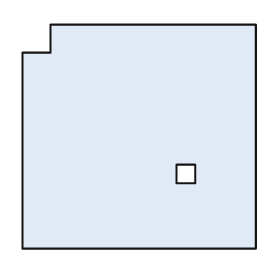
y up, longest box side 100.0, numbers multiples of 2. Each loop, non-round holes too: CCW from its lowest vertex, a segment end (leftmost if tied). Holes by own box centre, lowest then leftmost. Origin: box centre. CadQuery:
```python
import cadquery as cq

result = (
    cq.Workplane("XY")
    .moveTo(-50.0, -48.0)
    .lineTo(50.0, -48.0)
    .lineTo(50.0, 48.0)
    .lineTo(-38.0, 48.0)
    .lineTo(-38.0, 36.0)
    .lineTo(-50.0, 36.0)
    .close()
    .moveTo(16.0, -20.0)
    .lineTo(24.0, -20.0)
    .lineTo(24.0, -12.0)
    .lineTo(16.0, -12.0)
    .close()
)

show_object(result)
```